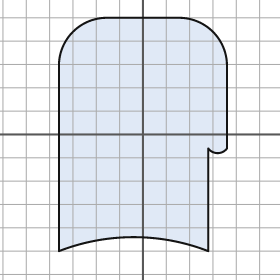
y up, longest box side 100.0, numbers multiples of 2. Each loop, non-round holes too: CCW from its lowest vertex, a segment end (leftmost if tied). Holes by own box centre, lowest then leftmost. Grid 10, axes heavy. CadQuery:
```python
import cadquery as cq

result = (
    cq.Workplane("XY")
    .moveTo(-36.0, -50.0)
    .threePointArc((-4.0, -44.0), (28.0, -50.0))
    .lineTo(28.0, -6.0)
    .threePointArc((32.0, -8.0), (36.0, -6.0))
    .lineTo(36.0, 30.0)
    .threePointArc((30.0, 44.0), (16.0, 50.0))
    .lineTo(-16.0, 50.0)
    .threePointArc((-30.0, 44.0), (-36.0, 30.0))
    .close()
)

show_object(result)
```